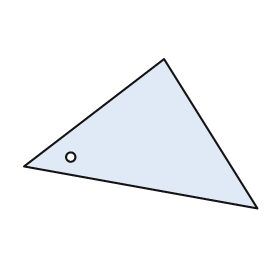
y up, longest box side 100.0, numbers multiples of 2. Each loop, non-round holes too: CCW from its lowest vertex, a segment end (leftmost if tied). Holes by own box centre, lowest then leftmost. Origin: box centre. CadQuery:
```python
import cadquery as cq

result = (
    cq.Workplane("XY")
    .moveTo(50.0, -32.0)
    .lineTo(10.0, 32.0)
    .lineTo(-50.0, -14.0)
    .close()
    .moveTo(-30.0, -10.0)
    .circle(2.0)
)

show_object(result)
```